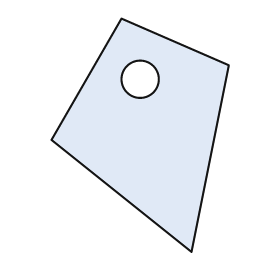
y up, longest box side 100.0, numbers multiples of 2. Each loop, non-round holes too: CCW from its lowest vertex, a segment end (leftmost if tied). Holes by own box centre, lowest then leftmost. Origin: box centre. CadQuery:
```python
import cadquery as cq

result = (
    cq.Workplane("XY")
    .moveTo(22.0, -50.0)
    .lineTo(38.0, 30.0)
    .lineTo(-8.0, 50.0)
    .lineTo(-38.0, -2.0)
    .close()
    .moveTo(0.0, 24.0)
    .circle(8.0)
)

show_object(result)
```